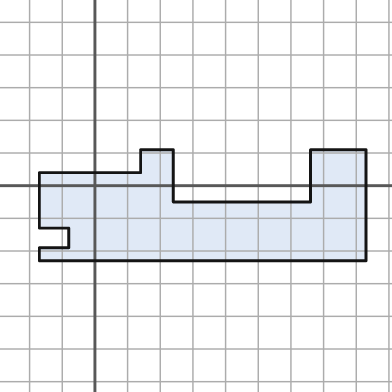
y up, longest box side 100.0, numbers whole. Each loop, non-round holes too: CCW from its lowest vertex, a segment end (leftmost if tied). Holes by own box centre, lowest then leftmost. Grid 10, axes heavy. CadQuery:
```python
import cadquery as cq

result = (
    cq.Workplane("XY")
    .moveTo(-17.0, -23.0)
    .lineTo(83.0, -23.0)
    .lineTo(83.0, 11.0)
    .lineTo(66.0, 11.0)
    .lineTo(66.0, -5.0)
    .lineTo(24.0, -5.0)
    .lineTo(24.0, 11.0)
    .lineTo(14.0, 11.0)
    .lineTo(14.0, 4.0)
    .lineTo(-17.0, 4.0)
    .lineTo(-17.0, -13.0)
    .lineTo(-8.0, -13.0)
    .lineTo(-8.0, -19.0)
    .lineTo(-17.0, -19.0)
    .close()
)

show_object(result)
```